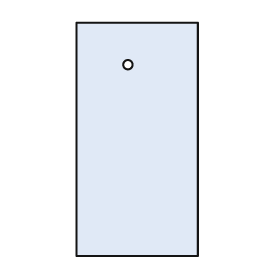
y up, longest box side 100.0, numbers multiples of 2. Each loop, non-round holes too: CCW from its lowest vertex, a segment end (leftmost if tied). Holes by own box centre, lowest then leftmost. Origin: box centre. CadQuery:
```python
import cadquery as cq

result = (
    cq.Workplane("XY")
    .moveTo(-26.0, -50.0)
    .lineTo(26.0, -50.0)
    .lineTo(26.0, 50.0)
    .lineTo(-26.0, 50.0)
    .close()
    .moveTo(-4.0, 32.0)
    .circle(2.0)
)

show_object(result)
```